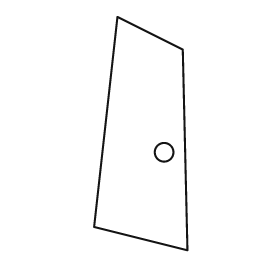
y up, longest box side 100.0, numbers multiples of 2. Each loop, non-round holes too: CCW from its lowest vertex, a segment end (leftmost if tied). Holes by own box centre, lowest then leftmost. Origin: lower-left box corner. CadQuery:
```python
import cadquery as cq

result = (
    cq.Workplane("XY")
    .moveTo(40.0, 0.0)
    .lineTo(38.0, 86.0)
    .lineTo(10.0, 100.0)
    .lineTo(0.0, 10.0)
    .close()
    .moveTo(30.0, 42.0)
    .circle(4.0)
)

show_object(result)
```